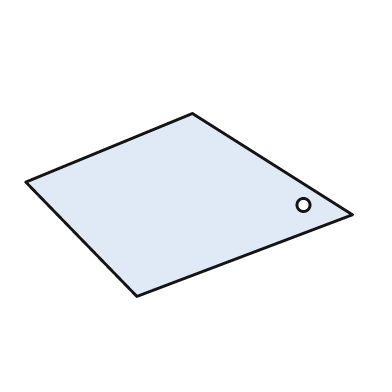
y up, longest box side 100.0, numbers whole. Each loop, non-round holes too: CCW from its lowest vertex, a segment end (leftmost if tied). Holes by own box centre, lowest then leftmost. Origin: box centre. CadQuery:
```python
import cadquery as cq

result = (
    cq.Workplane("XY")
    .moveTo(-16.0, -28.0)
    .lineTo(50.0, -3.0)
    .lineTo(1.0, 28.0)
    .lineTo(-50.0, 7.0)
    .close()
    .moveTo(35.0, 0.0)
    .circle(2.0)
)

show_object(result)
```